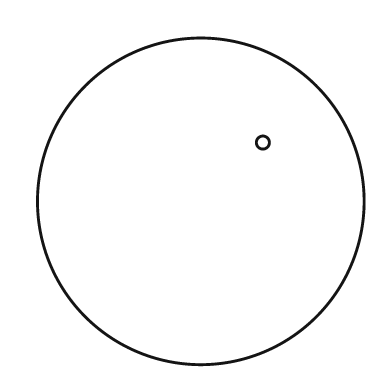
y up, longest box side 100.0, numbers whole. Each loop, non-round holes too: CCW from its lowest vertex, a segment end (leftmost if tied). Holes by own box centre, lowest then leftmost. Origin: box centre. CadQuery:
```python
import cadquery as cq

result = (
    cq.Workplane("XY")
    .moveTo(0.0, 0.0)
    .circle(50.0)
    .moveTo(19.0, 18.0)
    .circle(2.0)
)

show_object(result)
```